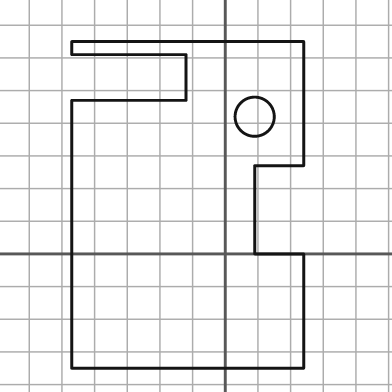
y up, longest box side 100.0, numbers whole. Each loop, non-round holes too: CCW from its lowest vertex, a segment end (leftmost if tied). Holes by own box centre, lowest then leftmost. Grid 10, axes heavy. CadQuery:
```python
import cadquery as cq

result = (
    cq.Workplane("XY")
    .moveTo(-47.0, -35.0)
    .lineTo(24.0, -35.0)
    .lineTo(24.0, 0.0)
    .lineTo(9.0, 0.0)
    .lineTo(9.0, 27.0)
    .lineTo(24.0, 27.0)
    .lineTo(24.0, 65.0)
    .lineTo(-47.0, 65.0)
    .lineTo(-47.0, 61.0)
    .lineTo(-12.0, 61.0)
    .lineTo(-12.0, 47.0)
    .lineTo(-47.0, 47.0)
    .close()
    .moveTo(9.0, 42.0)
    .circle(6.0)
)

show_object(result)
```